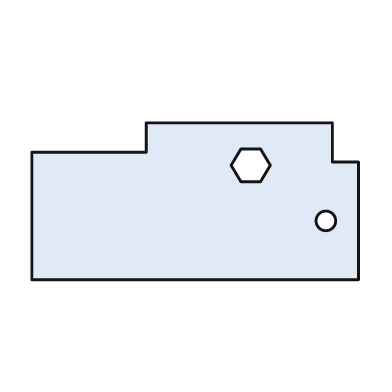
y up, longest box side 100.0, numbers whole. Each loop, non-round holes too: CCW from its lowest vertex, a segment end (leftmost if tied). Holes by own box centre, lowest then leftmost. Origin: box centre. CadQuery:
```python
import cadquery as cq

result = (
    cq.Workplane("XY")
    .moveTo(-50.0, -24.0)
    .lineTo(50.0, -24.0)
    .lineTo(50.0, 12.0)
    .lineTo(42.0, 12.0)
    .lineTo(42.0, 24.0)
    .lineTo(-15.0, 24.0)
    .lineTo(-15.0, 15.0)
    .lineTo(-50.0, 15.0)
    .close()
    .moveTo(40.0, -6.0)
    .circle(3.0)
    .moveTo(14.0, 6.0)
    .lineTo(20.0, 6.0)
    .lineTo(23.0, 11.0)
    .lineTo(20.0, 16.0)
    .lineTo(14.0, 16.0)
    .lineTo(11.0, 11.0)
    .close()
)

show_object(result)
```